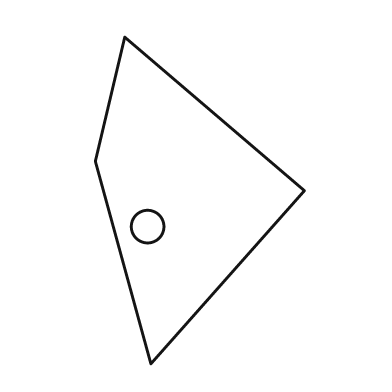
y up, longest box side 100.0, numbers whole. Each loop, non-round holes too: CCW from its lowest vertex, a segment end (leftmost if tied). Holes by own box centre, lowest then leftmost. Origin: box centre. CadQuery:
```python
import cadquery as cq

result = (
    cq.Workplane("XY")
    .moveTo(-15.0, -50.0)
    .lineTo(32.0, 3.0)
    .lineTo(-23.0, 50.0)
    .lineTo(-32.0, 12.0)
    .close()
    .moveTo(-16.0, -8.0)
    .circle(5.0)
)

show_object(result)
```